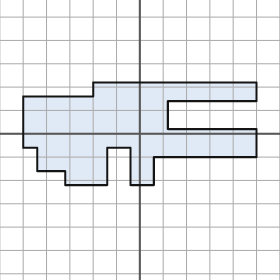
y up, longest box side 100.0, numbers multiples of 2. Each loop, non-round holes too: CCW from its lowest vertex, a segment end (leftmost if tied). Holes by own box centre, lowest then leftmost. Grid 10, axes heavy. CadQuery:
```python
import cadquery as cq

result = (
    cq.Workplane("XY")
    .moveTo(-32.0, -22.0)
    .lineTo(-14.0, -22.0)
    .lineTo(-14.0, -6.0)
    .lineTo(-4.0, -6.0)
    .lineTo(-4.0, -22.0)
    .lineTo(6.0, -22.0)
    .lineTo(6.0, -10.0)
    .lineTo(50.0, -10.0)
    .lineTo(50.0, 2.0)
    .lineTo(12.0, 2.0)
    .lineTo(12.0, 14.0)
    .lineTo(50.0, 14.0)
    .lineTo(50.0, 22.0)
    .lineTo(-20.0, 22.0)
    .lineTo(-20.0, 16.0)
    .lineTo(-50.0, 16.0)
    .lineTo(-50.0, -6.0)
    .lineTo(-44.0, -6.0)
    .lineTo(-44.0, -16.0)
    .lineTo(-32.0, -16.0)
    .close()
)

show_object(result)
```